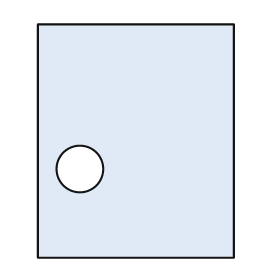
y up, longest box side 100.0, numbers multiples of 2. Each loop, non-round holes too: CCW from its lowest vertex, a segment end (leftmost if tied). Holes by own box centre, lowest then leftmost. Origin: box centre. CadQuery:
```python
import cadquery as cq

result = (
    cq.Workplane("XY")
    .moveTo(-42.0, -50.0)
    .lineTo(42.0, -50.0)
    .lineTo(42.0, 50.0)
    .lineTo(-42.0, 50.0)
    .close()
    .moveTo(-24.0, -12.0)
    .circle(10.0)
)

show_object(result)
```